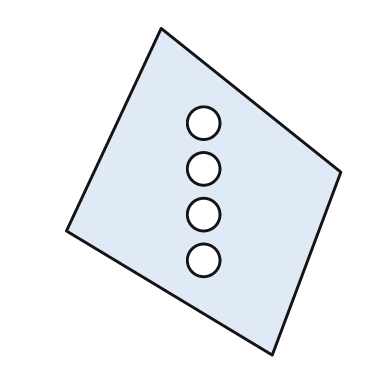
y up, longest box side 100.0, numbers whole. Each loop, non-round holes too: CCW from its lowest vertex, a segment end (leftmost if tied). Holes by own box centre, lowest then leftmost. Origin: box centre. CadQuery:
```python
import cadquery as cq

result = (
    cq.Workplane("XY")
    .moveTo(21.0, -50.0)
    .lineTo(42.0, 6.0)
    .lineTo(-13.0, 50.0)
    .lineTo(-42.0, -12.0)
    .close()
    .moveTo(0.0, -21.0)
    .circle(5.0)
    .moveTo(0.0, -7.0)
    .circle(5.0)
    .moveTo(0.0, 7.0)
    .circle(5.0)
    .moveTo(0.0, 21.0)
    .circle(5.0)
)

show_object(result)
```